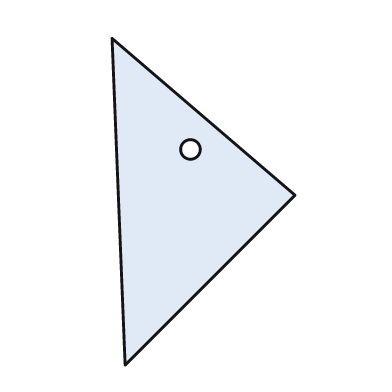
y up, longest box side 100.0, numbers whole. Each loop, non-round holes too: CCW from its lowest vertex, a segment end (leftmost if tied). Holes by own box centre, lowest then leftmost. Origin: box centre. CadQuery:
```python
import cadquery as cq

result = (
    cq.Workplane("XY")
    .moveTo(-24.0, -50.0)
    .lineTo(28.0, 2.0)
    .lineTo(-28.0, 50.0)
    .close()
    .moveTo(-4.0, 16.0)
    .circle(3.0)
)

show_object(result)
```